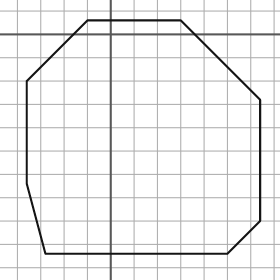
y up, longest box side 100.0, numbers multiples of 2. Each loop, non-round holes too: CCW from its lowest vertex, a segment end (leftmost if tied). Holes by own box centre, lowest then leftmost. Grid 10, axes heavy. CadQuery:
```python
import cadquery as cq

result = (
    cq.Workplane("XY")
    .moveTo(-28.0, -94.0)
    .lineTo(50.0, -94.0)
    .lineTo(64.0, -80.0)
    .lineTo(64.0, -28.0)
    .lineTo(30.0, 6.0)
    .lineTo(-10.0, 6.0)
    .lineTo(-36.0, -20.0)
    .lineTo(-36.0, -64.0)
    .close()
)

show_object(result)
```